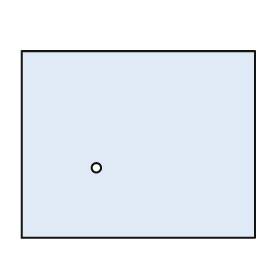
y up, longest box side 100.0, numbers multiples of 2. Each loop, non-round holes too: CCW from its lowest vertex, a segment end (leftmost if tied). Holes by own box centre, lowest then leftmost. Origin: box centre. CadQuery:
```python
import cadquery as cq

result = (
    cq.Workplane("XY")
    .moveTo(-50.0, -40.0)
    .lineTo(50.0, -40.0)
    .lineTo(50.0, 40.0)
    .lineTo(-50.0, 40.0)
    .close()
    .moveTo(-18.0, -10.0)
    .circle(2.0)
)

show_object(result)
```